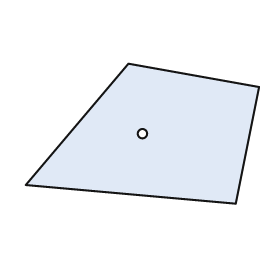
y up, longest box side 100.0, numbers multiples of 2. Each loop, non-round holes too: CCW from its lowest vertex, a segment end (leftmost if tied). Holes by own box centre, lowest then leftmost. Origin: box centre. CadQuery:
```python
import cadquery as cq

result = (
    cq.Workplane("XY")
    .moveTo(40.0, -30.0)
    .lineTo(50.0, 20.0)
    .lineTo(-6.0, 30.0)
    .lineTo(-50.0, -22.0)
    .close()
    .moveTo(0.0, 0.0)
    .circle(2.0)
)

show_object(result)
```